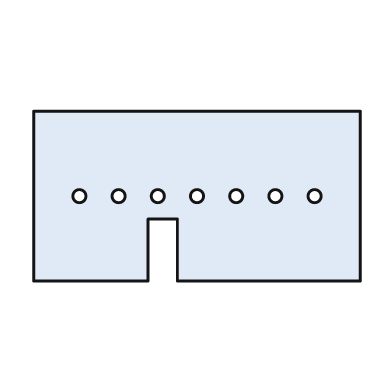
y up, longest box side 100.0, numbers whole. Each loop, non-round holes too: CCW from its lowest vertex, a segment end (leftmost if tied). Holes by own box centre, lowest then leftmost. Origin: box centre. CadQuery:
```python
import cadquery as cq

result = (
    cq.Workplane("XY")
    .moveTo(-50.0, -26.0)
    .lineTo(-15.0, -26.0)
    .lineTo(-15.0, -7.0)
    .lineTo(-6.0, -7.0)
    .lineTo(-6.0, -26.0)
    .lineTo(50.0, -26.0)
    .lineTo(50.0, 26.0)
    .lineTo(-50.0, 26.0)
    .close()
    .moveTo(-36.0, 0.0)
    .circle(2.0)
    .moveTo(-24.0, 0.0)
    .circle(2.0)
    .moveTo(-12.0, 0.0)
    .circle(2.0)
    .moveTo(0.0, 0.0)
    .circle(2.0)
    .moveTo(12.0, 0.0)
    .circle(2.0)
    .moveTo(24.0, 0.0)
    .circle(2.0)
    .moveTo(36.0, 0.0)
    .circle(2.0)
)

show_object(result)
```